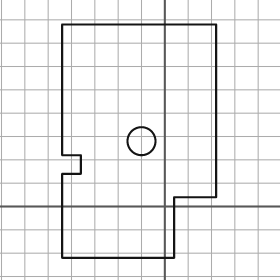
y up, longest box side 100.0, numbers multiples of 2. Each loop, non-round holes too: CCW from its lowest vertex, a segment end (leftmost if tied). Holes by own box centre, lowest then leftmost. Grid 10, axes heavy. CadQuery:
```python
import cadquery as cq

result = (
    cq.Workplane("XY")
    .moveTo(-44.0, -22.0)
    .lineTo(4.0, -22.0)
    .lineTo(4.0, 4.0)
    .lineTo(22.0, 4.0)
    .lineTo(22.0, 78.0)
    .lineTo(-44.0, 78.0)
    .lineTo(-44.0, 22.0)
    .lineTo(-36.0, 22.0)
    .lineTo(-36.0, 14.0)
    .lineTo(-44.0, 14.0)
    .close()
    .moveTo(-10.0, 28.0)
    .circle(6.0)
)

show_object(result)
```